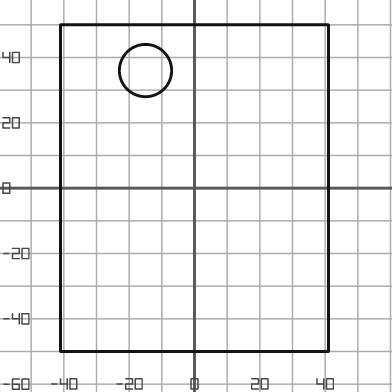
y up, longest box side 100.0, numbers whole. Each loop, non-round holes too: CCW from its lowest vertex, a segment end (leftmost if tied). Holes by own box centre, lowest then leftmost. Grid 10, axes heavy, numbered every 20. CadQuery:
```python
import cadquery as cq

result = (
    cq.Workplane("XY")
    .moveTo(-41.0, -50.0)
    .lineTo(41.0, -50.0)
    .lineTo(41.0, 50.0)
    .lineTo(-41.0, 50.0)
    .close()
    .moveTo(-15.0, 36.0)
    .circle(8.0)
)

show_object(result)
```